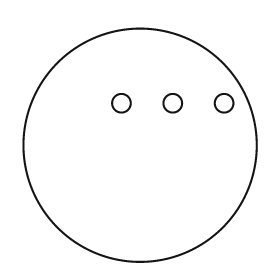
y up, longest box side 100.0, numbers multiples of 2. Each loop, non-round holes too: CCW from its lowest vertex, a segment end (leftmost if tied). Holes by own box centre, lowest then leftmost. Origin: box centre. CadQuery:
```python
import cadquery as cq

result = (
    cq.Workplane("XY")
    .moveTo(0.0, 0.0)
    .circle(50.0)
    .moveTo(-8.0, 18.0)
    .circle(4.0)
    .moveTo(14.0, 18.0)
    .circle(4.0)
    .moveTo(36.0, 18.0)
    .circle(4.0)
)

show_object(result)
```